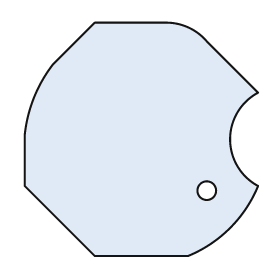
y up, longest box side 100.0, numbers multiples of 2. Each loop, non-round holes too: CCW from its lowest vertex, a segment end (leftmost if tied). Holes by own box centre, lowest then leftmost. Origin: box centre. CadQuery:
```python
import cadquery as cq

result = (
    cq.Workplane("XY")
    .moveTo(-20.0, -50.0)
    .lineTo(20.0, -50.0)
    .threePointArc((38.0, -38.0), (50.0, -20.0))
    .threePointArc((38.0, 0.0), (50.0, 20.0))
    .lineTo(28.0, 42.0)
    .threePointArc((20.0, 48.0), (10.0, 50.0))
    .lineTo(-20.0, 50.0)
    .lineTo(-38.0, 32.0)
    .threePointArc((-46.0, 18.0), (-50.0, 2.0))
    .lineTo(-50.0, -20.0)
    .close()
    .moveTo(28.0, -22.0)
    .circle(4.0)
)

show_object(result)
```